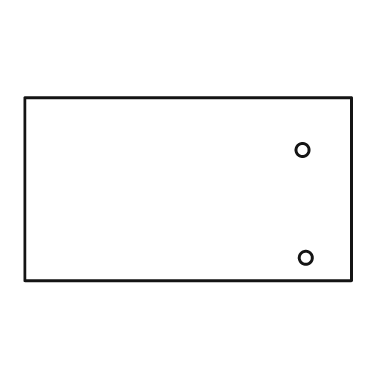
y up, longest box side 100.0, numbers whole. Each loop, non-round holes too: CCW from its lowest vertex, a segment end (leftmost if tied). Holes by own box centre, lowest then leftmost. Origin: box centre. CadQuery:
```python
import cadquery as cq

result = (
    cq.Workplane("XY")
    .moveTo(-50.0, -28.0)
    .lineTo(50.0, -28.0)
    .lineTo(50.0, 28.0)
    .lineTo(-50.0, 28.0)
    .close()
    .moveTo(36.0, -21.0)
    .circle(2.0)
    .moveTo(35.0, 12.0)
    .circle(2.0)
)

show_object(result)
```